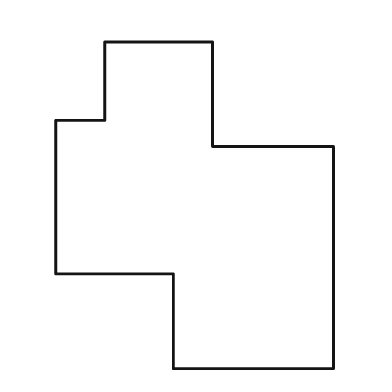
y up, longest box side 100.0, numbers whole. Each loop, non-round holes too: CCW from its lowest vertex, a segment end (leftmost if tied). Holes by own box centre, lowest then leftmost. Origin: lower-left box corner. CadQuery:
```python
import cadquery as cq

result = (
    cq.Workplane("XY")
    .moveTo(36.0, 0.0)
    .lineTo(85.0, 0.0)
    .lineTo(85.0, 68.0)
    .lineTo(48.0, 68.0)
    .lineTo(48.0, 100.0)
    .lineTo(15.0, 100.0)
    .lineTo(15.0, 76.0)
    .lineTo(0.0, 76.0)
    .lineTo(0.0, 29.0)
    .lineTo(36.0, 29.0)
    .close()
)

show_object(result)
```